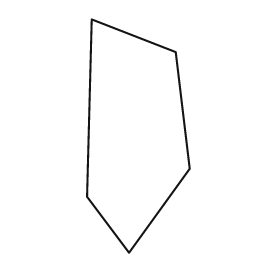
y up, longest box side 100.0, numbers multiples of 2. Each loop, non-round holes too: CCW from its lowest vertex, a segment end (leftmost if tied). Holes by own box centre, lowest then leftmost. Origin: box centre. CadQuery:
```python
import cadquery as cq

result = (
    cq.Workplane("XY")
    .moveTo(-4.0, -50.0)
    .lineTo(22.0, -14.0)
    .lineTo(16.0, 36.0)
    .lineTo(-20.0, 50.0)
    .lineTo(-22.0, -26.0)
    .close()
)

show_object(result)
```